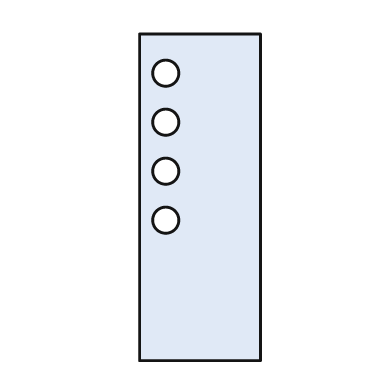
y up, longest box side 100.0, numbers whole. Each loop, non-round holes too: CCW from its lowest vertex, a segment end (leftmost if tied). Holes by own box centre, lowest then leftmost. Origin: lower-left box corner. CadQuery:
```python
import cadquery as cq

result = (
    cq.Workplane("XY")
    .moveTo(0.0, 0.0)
    .lineTo(37.0, 0.0)
    .lineTo(37.0, 100.0)
    .lineTo(0.0, 100.0)
    .close()
    .moveTo(8.0, 43.0)
    .circle(4.0)
    .moveTo(8.0, 58.0)
    .circle(4.0)
    .moveTo(8.0, 73.0)
    .circle(4.0)
    .moveTo(8.0, 88.0)
    .circle(4.0)
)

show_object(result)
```